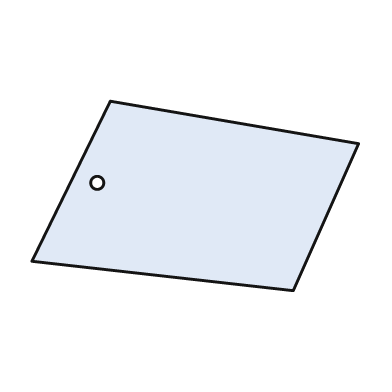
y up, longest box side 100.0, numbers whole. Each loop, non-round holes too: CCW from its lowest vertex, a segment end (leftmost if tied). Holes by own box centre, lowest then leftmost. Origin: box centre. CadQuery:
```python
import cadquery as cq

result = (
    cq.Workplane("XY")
    .moveTo(30.0, -29.0)
    .lineTo(50.0, 16.0)
    .lineTo(-26.0, 29.0)
    .lineTo(-50.0, -20.0)
    .close()
    .moveTo(-30.0, 4.0)
    .circle(2.0)
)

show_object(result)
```